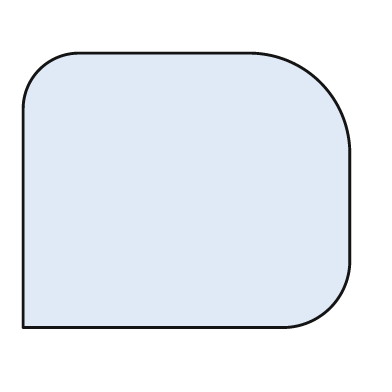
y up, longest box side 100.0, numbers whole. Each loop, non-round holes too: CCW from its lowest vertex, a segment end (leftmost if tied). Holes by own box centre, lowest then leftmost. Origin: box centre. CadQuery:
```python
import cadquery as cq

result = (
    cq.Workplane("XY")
    .moveTo(-50.0, -42.0)
    .lineTo(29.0, -42.0)
    .threePointArc((44.0, -36.0), (50.0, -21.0))
    .lineTo(50.0, 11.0)
    .threePointArc((41.0, 33.0), (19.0, 42.0))
    .lineTo(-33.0, 42.0)
    .threePointArc((-45.0, 37.0), (-50.0, 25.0))
    .close()
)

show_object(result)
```